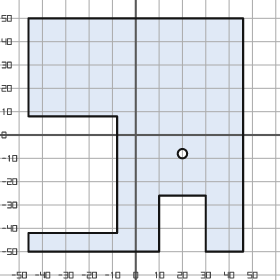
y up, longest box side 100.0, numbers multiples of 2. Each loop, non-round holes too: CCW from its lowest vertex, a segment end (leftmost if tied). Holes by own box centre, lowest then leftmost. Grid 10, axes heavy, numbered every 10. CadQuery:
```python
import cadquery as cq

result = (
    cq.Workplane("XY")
    .moveTo(-46.0, -50.0)
    .lineTo(10.0, -50.0)
    .lineTo(10.0, -26.0)
    .lineTo(30.0, -26.0)
    .lineTo(30.0, -50.0)
    .lineTo(46.0, -50.0)
    .lineTo(46.0, 50.0)
    .lineTo(-46.0, 50.0)
    .lineTo(-46.0, 8.0)
    .lineTo(-8.0, 8.0)
    .lineTo(-8.0, -42.0)
    .lineTo(-46.0, -42.0)
    .close()
    .moveTo(20.0, -8.0)
    .circle(2.0)
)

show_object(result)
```